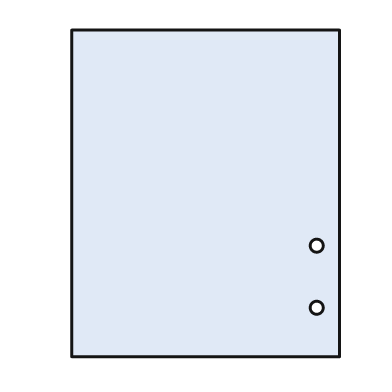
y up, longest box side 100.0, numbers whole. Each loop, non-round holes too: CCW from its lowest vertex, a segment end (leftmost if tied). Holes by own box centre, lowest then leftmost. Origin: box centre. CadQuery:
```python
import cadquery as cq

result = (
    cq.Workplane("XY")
    .moveTo(-41.0, -50.0)
    .lineTo(41.0, -50.0)
    .lineTo(41.0, 50.0)
    .lineTo(-41.0, 50.0)
    .close()
    .moveTo(34.0, -35.0)
    .circle(2.0)
    .moveTo(34.0, -16.0)
    .circle(2.0)
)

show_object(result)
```